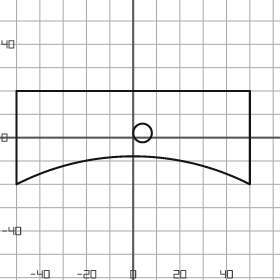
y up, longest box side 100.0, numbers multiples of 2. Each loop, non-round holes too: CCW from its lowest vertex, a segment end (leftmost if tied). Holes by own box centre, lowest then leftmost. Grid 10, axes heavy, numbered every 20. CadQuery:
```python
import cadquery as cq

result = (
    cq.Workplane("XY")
    .moveTo(-50.0, -20.0)
    .threePointArc((0.0, -8.0), (50.0, -20.0))
    .lineTo(50.0, 20.0)
    .lineTo(-50.0, 20.0)
    .close()
    .moveTo(4.0, 2.0)
    .circle(4.0)
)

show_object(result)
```